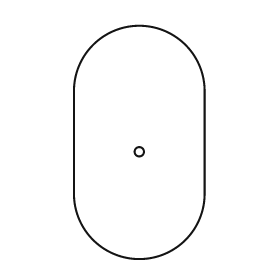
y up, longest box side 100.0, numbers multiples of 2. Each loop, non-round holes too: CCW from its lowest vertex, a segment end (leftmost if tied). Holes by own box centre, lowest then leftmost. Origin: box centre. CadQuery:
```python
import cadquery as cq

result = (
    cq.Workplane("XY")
    .moveTo(-28.0, -22.0)
    .threePointArc((0.0, -50.0), (28.0, -22.0))
    .lineTo(28.0, 22.0)
    .threePointArc((0.0, 50.0), (-28.0, 22.0))
    .close()
    .moveTo(0.0, -4.0)
    .circle(2.0)
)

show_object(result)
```